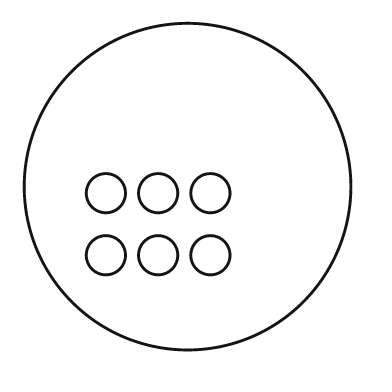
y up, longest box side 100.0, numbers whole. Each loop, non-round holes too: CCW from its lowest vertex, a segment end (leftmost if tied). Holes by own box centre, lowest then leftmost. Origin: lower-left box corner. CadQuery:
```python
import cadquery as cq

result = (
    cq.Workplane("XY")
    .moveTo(50.0, 50.0)
    .circle(50.0)
    .moveTo(25.0, 29.0)
    .circle(6.0)
    .moveTo(41.0, 29.0)
    .circle(6.0)
    .moveTo(57.0, 29.0)
    .circle(6.0)
    .moveTo(25.0, 48.0)
    .circle(6.0)
    .moveTo(41.0, 48.0)
    .circle(6.0)
    .moveTo(57.0, 48.0)
    .circle(6.0)
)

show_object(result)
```